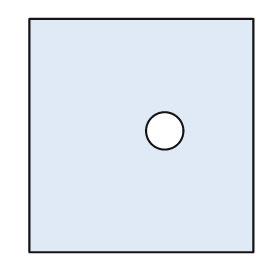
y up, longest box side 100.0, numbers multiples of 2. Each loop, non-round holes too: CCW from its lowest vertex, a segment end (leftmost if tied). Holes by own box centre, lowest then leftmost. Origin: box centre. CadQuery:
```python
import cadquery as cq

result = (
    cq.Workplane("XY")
    .moveTo(-48.0, -50.0)
    .lineTo(48.0, -50.0)
    .lineTo(48.0, 50.0)
    .lineTo(-48.0, 50.0)
    .close()
    .moveTo(10.0, 2.0)
    .circle(8.0)
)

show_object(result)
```